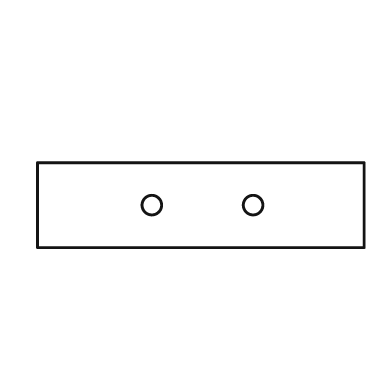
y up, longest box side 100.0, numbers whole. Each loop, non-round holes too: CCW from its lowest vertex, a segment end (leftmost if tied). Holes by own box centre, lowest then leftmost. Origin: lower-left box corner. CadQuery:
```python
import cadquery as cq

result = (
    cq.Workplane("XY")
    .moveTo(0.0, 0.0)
    .lineTo(100.0, 0.0)
    .lineTo(100.0, 26.0)
    .lineTo(0.0, 26.0)
    .close()
    .moveTo(35.0, 13.0)
    .circle(3.0)
    .moveTo(66.0, 13.0)
    .circle(3.0)
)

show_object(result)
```